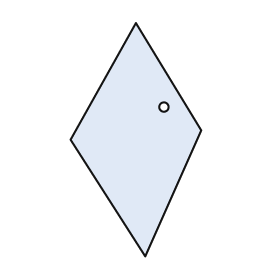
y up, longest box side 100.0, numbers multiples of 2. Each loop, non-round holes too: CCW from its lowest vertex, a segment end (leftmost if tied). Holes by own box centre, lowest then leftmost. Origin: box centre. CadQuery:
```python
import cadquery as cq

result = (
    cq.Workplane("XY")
    .moveTo(4.0, -50.0)
    .lineTo(28.0, 4.0)
    .lineTo(0.0, 50.0)
    .lineTo(-28.0, 0.0)
    .close()
    .moveTo(12.0, 14.0)
    .circle(2.0)
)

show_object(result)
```